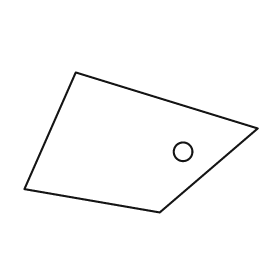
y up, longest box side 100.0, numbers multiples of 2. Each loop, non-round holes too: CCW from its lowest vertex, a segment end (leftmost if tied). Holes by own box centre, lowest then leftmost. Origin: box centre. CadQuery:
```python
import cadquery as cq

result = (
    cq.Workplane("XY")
    .moveTo(8.0, -30.0)
    .lineTo(50.0, 6.0)
    .lineTo(-28.0, 30.0)
    .lineTo(-50.0, -20.0)
    .close()
    .moveTo(18.0, -4.0)
    .circle(4.0)
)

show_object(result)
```